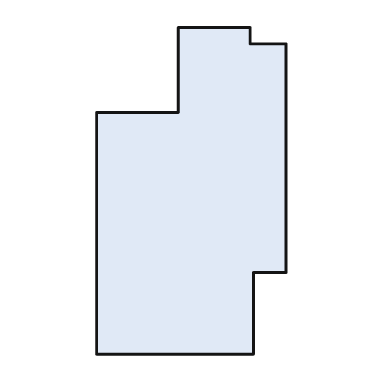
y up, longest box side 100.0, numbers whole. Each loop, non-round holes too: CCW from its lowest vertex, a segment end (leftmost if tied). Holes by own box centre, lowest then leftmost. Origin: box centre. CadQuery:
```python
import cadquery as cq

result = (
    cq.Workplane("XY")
    .moveTo(-29.0, -50.0)
    .lineTo(19.0, -50.0)
    .lineTo(19.0, -25.0)
    .lineTo(29.0, -25.0)
    .lineTo(29.0, 45.0)
    .lineTo(18.0, 45.0)
    .lineTo(18.0, 50.0)
    .lineTo(-4.0, 50.0)
    .lineTo(-4.0, 24.0)
    .lineTo(-29.0, 24.0)
    .close()
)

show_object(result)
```